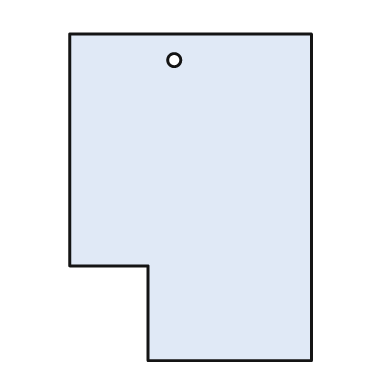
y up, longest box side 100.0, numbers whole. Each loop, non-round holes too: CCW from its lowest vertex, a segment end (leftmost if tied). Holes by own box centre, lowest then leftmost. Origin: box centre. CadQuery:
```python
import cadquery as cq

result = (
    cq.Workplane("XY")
    .moveTo(-13.0, -50.0)
    .lineTo(37.0, -50.0)
    .lineTo(37.0, 50.0)
    .lineTo(-37.0, 50.0)
    .lineTo(-37.0, -21.0)
    .lineTo(-13.0, -21.0)
    .close()
    .moveTo(-5.0, 42.0)
    .circle(2.0)
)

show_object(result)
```